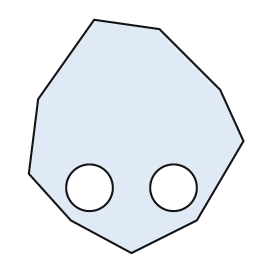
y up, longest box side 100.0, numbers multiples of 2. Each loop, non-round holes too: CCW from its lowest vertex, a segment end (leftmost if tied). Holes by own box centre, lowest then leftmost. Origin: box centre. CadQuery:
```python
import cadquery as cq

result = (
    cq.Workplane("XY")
    .moveTo(-2.0, -50.0)
    .lineTo(26.0, -36.0)
    .lineTo(46.0, -2.0)
    .lineTo(36.0, 20.0)
    .lineTo(10.0, 46.0)
    .lineTo(-18.0, 50.0)
    .lineTo(-42.0, 16.0)
    .lineTo(-46.0, -16.0)
    .lineTo(-28.0, -36.0)
    .close()
    .moveTo(-20.0, -22.0)
    .circle(10.0)
    .moveTo(16.0, -22.0)
    .circle(10.0)
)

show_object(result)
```